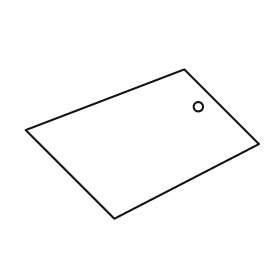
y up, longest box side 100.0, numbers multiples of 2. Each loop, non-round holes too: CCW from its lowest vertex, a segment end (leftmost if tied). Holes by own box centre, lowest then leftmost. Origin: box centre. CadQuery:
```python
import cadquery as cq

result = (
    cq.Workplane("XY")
    .moveTo(-12.0, -32.0)
    .lineTo(50.0, 0.0)
    .lineTo(18.0, 32.0)
    .lineTo(-50.0, 6.0)
    .close()
    .moveTo(24.0, 16.0)
    .circle(2.0)
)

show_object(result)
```